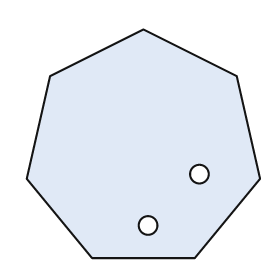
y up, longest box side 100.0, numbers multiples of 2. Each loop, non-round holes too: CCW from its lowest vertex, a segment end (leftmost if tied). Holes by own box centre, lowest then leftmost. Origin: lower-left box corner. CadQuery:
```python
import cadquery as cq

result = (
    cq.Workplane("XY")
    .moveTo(28.0, 0.0)
    .lineTo(72.0, 0.0)
    .lineTo(100.0, 34.0)
    .lineTo(90.0, 78.0)
    .lineTo(50.0, 98.0)
    .lineTo(10.0, 78.0)
    .lineTo(0.0, 34.0)
    .close()
    .moveTo(52.0, 14.0)
    .circle(4.0)
    .moveTo(74.0, 36.0)
    .circle(4.0)
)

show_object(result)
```